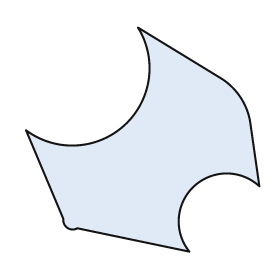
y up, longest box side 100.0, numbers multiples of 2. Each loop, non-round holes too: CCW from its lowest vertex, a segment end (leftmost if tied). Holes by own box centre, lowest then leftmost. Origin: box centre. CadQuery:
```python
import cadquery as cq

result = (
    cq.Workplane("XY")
    .moveTo(20.0, -48.0)
    .threePointArc((22.0, -20.0), (50.0, -20.0))
    .lineTo(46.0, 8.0)
    .threePointArc((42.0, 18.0), (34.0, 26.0))
    .lineTo(-2.0, 48.0)
    .threePointArc((-8.0, 6.0), (-50.0, 4.0))
    .lineTo(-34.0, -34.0)
    .threePointArc((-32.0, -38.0), (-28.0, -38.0))
    .close()
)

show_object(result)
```